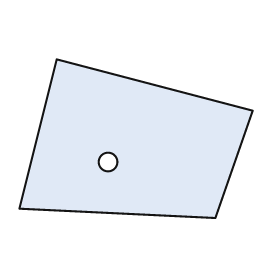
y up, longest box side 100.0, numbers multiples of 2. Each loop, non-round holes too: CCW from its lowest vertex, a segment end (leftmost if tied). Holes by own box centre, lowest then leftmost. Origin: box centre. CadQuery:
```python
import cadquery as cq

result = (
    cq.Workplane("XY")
    .moveTo(34.0, -34.0)
    .lineTo(50.0, 12.0)
    .lineTo(-34.0, 34.0)
    .lineTo(-50.0, -30.0)
    .close()
    .moveTo(-12.0, -10.0)
    .circle(4.0)
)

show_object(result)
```